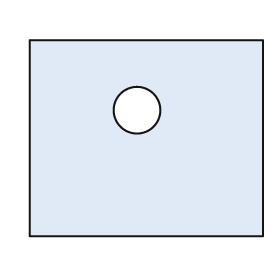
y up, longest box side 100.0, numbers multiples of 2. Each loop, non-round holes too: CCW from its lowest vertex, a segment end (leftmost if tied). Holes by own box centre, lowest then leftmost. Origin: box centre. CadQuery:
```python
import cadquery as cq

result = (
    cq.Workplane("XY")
    .moveTo(-50.0, -42.0)
    .lineTo(50.0, -42.0)
    .lineTo(50.0, 42.0)
    .lineTo(-50.0, 42.0)
    .close()
    .moveTo(-4.0, 12.0)
    .circle(10.0)
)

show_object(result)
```